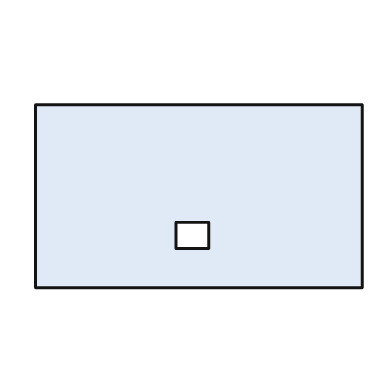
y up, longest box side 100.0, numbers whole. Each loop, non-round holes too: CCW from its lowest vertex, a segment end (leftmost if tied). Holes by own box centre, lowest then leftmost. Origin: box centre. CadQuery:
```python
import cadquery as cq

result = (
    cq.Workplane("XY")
    .moveTo(-50.0, -28.0)
    .lineTo(50.0, -28.0)
    .lineTo(50.0, 28.0)
    .lineTo(-50.0, 28.0)
    .close()
    .moveTo(-7.0, -16.0)
    .lineTo(3.0, -16.0)
    .lineTo(3.0, -8.0)
    .lineTo(-7.0, -8.0)
    .close()
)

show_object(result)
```